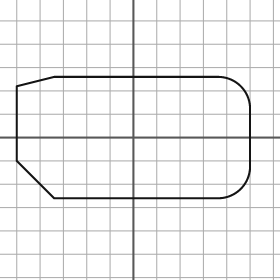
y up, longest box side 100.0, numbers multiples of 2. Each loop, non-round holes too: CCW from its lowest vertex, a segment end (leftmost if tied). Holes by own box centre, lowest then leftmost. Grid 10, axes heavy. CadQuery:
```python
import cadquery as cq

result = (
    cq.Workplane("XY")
    .moveTo(-34.0, -26.0)
    .lineTo(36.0, -26.0)
    .threePointArc((46.0, -22.0), (50.0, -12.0))
    .lineTo(50.0, 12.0)
    .threePointArc((46.0, 22.0), (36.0, 26.0))
    .lineTo(-34.0, 26.0)
    .lineTo(-50.0, 22.0)
    .lineTo(-50.0, -10.0)
    .close()
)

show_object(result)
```